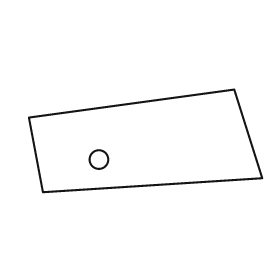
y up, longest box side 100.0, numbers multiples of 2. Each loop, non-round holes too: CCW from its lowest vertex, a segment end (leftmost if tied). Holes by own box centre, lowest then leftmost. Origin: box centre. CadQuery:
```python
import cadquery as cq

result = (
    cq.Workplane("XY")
    .moveTo(-44.0, -22.0)
    .lineTo(50.0, -16.0)
    .lineTo(38.0, 22.0)
    .lineTo(-50.0, 10.0)
    .close()
    .moveTo(-20.0, -8.0)
    .circle(4.0)
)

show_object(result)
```